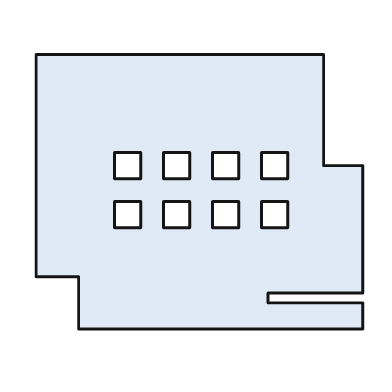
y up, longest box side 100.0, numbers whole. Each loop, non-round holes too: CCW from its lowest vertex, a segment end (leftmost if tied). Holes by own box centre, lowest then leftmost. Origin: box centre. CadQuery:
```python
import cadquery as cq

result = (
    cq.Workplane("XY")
    .moveTo(-37.0, -42.0)
    .lineTo(50.0, -42.0)
    .lineTo(50.0, -34.0)
    .lineTo(21.0, -34.0)
    .lineTo(21.0, -31.0)
    .lineTo(50.0, -31.0)
    .lineTo(50.0, 8.0)
    .lineTo(38.0, 8.0)
    .lineTo(38.0, 42.0)
    .lineTo(-50.0, 42.0)
    .lineTo(-50.0, -26.0)
    .lineTo(-37.0, -26.0)
    .close()
    .moveTo(-26.0, -11.0)
    .lineTo(-18.0, -11.0)
    .lineTo(-18.0, -3.0)
    .lineTo(-26.0, -3.0)
    .close()
    .moveTo(-11.0, -11.0)
    .lineTo(-3.0, -11.0)
    .lineTo(-3.0, -3.0)
    .lineTo(-11.0, -3.0)
    .close()
    .moveTo(4.0, -11.0)
    .lineTo(12.0, -11.0)
    .lineTo(12.0, -3.0)
    .lineTo(4.0, -3.0)
    .close()
    .moveTo(19.0, -11.0)
    .lineTo(27.0, -11.0)
    .lineTo(27.0, -3.0)
    .lineTo(19.0, -3.0)
    .close()
    .moveTo(-26.0, 4.0)
    .lineTo(-18.0, 4.0)
    .lineTo(-18.0, 12.0)
    .lineTo(-26.0, 12.0)
    .close()
    .moveTo(-11.0, 4.0)
    .lineTo(-3.0, 4.0)
    .lineTo(-3.0, 12.0)
    .lineTo(-11.0, 12.0)
    .close()
    .moveTo(4.0, 4.0)
    .lineTo(12.0, 4.0)
    .lineTo(12.0, 12.0)
    .lineTo(4.0, 12.0)
    .close()
    .moveTo(19.0, 4.0)
    .lineTo(27.0, 4.0)
    .lineTo(27.0, 12.0)
    .lineTo(19.0, 12.0)
    .close()
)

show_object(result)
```